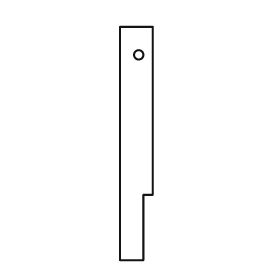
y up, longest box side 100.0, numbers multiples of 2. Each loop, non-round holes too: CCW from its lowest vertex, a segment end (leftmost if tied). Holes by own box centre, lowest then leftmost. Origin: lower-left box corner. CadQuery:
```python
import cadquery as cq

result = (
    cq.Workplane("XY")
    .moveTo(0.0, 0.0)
    .lineTo(10.0, 0.0)
    .lineTo(10.0, 28.0)
    .lineTo(14.0, 28.0)
    .lineTo(14.0, 100.0)
    .lineTo(0.0, 100.0)
    .close()
    .moveTo(8.0, 88.0)
    .circle(2.0)
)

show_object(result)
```